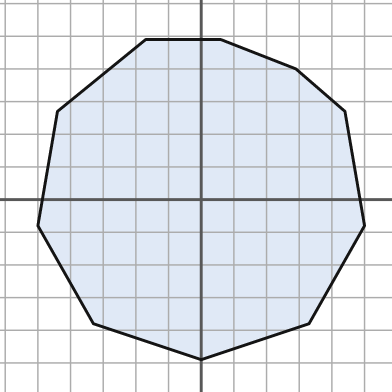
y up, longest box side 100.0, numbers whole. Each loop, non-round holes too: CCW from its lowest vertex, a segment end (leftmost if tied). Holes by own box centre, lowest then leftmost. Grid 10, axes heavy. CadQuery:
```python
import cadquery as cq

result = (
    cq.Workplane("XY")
    .moveTo(0.0, -49.0)
    .lineTo(33.0, -38.0)
    .lineTo(50.0, -8.0)
    .lineTo(44.0, 27.0)
    .lineTo(29.0, 40.0)
    .lineTo(6.0, 49.0)
    .lineTo(-17.0, 49.0)
    .lineTo(-44.0, 27.0)
    .lineTo(-50.0, -8.0)
    .lineTo(-33.0, -38.0)
    .close()
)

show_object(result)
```